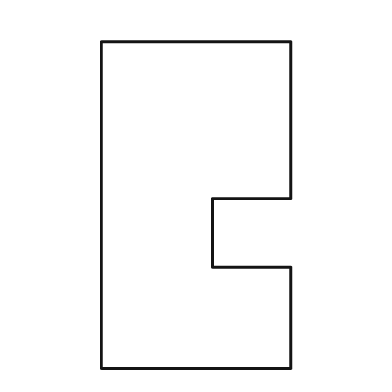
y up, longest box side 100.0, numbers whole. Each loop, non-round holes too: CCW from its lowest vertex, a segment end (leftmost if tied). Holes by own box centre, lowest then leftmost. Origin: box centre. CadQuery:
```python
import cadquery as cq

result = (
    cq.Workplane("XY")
    .moveTo(-29.0, -50.0)
    .lineTo(29.0, -50.0)
    .lineTo(29.0, -19.0)
    .lineTo(5.0, -19.0)
    .lineTo(5.0, 2.0)
    .lineTo(29.0, 2.0)
    .lineTo(29.0, 50.0)
    .lineTo(-29.0, 50.0)
    .close()
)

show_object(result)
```